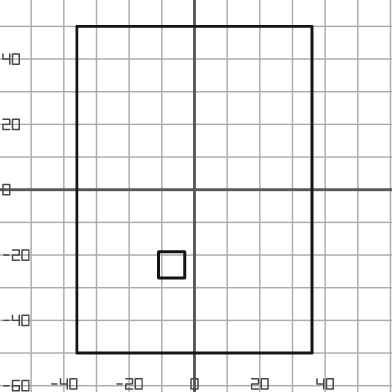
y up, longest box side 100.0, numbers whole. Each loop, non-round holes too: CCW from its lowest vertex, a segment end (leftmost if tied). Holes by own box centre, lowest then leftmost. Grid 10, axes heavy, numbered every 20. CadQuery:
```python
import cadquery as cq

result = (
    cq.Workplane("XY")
    .moveTo(-36.0, -50.0)
    .lineTo(36.0, -50.0)
    .lineTo(36.0, 50.0)
    .lineTo(-36.0, 50.0)
    .close()
    .moveTo(-11.0, -27.0)
    .lineTo(-3.0, -27.0)
    .lineTo(-3.0, -19.0)
    .lineTo(-11.0, -19.0)
    .close()
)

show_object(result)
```